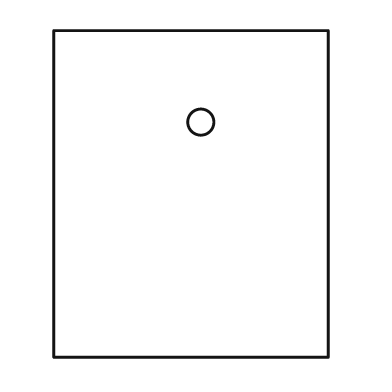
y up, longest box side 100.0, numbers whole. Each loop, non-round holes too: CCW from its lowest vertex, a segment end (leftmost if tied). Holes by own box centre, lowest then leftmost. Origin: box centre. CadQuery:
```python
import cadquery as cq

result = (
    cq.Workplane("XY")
    .moveTo(-42.0, -50.0)
    .lineTo(42.0, -50.0)
    .lineTo(42.0, 50.0)
    .lineTo(-42.0, 50.0)
    .close()
    .moveTo(3.0, 22.0)
    .circle(4.0)
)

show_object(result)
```